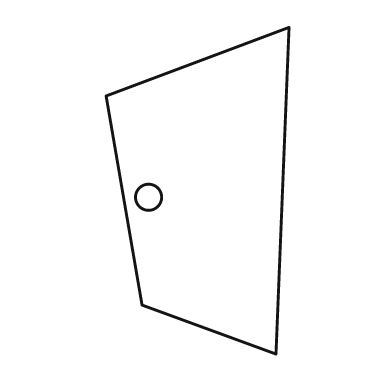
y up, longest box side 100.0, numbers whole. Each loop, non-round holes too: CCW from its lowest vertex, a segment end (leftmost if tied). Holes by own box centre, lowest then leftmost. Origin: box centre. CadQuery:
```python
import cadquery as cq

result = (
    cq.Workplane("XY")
    .moveTo(24.0, -50.0)
    .lineTo(28.0, 50.0)
    .lineTo(-28.0, 29.0)
    .lineTo(-17.0, -35.0)
    .close()
    .moveTo(-15.0, -2.0)
    .circle(4.0)
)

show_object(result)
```